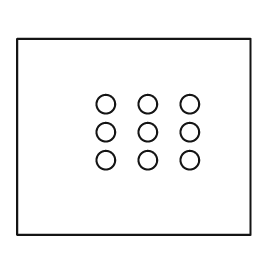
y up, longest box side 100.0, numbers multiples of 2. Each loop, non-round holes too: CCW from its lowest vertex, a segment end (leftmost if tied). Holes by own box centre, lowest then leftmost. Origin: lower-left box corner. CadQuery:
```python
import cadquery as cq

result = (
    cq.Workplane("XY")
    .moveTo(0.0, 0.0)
    .lineTo(100.0, 0.0)
    .lineTo(100.0, 84.0)
    .lineTo(0.0, 84.0)
    .close()
    .moveTo(38.0, 32.0)
    .circle(4.0)
    .moveTo(56.0, 32.0)
    .circle(4.0)
    .moveTo(74.0, 32.0)
    .circle(4.0)
    .moveTo(38.0, 44.0)
    .circle(4.0)
    .moveTo(56.0, 44.0)
    .circle(4.0)
    .moveTo(74.0, 44.0)
    .circle(4.0)
    .moveTo(38.0, 56.0)
    .circle(4.0)
    .moveTo(56.0, 56.0)
    .circle(4.0)
    .moveTo(74.0, 56.0)
    .circle(4.0)
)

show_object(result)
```